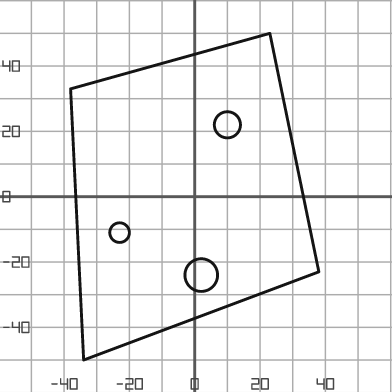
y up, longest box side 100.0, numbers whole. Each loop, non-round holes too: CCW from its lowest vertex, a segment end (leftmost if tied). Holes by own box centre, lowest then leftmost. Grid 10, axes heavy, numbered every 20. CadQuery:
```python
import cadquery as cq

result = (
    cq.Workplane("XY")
    .moveTo(-34.0, -50.0)
    .lineTo(38.0, -23.0)
    .lineTo(23.0, 50.0)
    .lineTo(-38.0, 33.0)
    .close()
    .moveTo(2.0, -24.0)
    .circle(5.0)
    .moveTo(-23.0, -11.0)
    .circle(3.0)
    .moveTo(10.0, 22.0)
    .circle(4.0)
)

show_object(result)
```